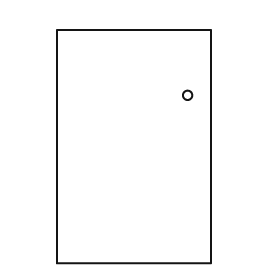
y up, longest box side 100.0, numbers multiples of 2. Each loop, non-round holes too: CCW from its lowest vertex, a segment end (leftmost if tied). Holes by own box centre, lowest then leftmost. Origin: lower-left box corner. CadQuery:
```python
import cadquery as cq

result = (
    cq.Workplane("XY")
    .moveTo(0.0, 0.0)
    .lineTo(66.0, 0.0)
    .lineTo(66.0, 100.0)
    .lineTo(0.0, 100.0)
    .close()
    .moveTo(56.0, 72.0)
    .circle(2.0)
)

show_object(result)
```